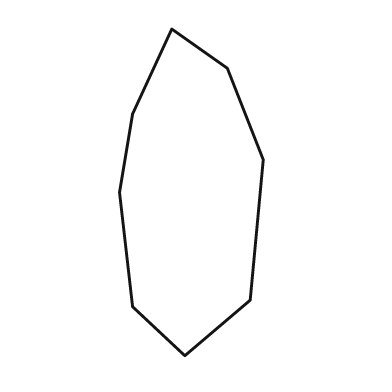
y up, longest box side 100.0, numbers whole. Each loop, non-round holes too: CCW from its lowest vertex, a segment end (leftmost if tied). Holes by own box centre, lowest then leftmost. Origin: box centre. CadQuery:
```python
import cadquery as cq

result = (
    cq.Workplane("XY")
    .moveTo(-2.0, -50.0)
    .lineTo(18.0, -33.0)
    .lineTo(22.0, 10.0)
    .lineTo(11.0, 38.0)
    .lineTo(-6.0, 50.0)
    .lineTo(-18.0, 24.0)
    .lineTo(-22.0, 0.0)
    .lineTo(-18.0, -35.0)
    .close()
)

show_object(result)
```